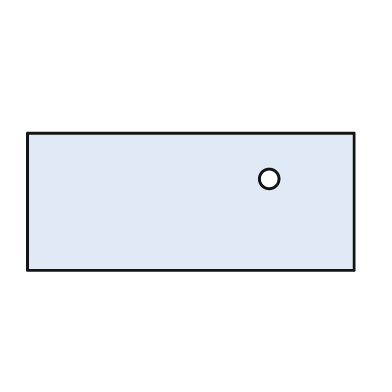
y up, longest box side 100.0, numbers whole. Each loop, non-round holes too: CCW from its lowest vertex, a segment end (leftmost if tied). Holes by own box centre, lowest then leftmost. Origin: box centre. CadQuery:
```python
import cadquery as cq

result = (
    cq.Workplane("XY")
    .moveTo(-50.0, -21.0)
    .lineTo(50.0, -21.0)
    .lineTo(50.0, 21.0)
    .lineTo(-50.0, 21.0)
    .close()
    .moveTo(24.0, 7.0)
    .circle(3.0)
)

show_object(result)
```